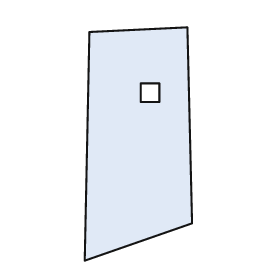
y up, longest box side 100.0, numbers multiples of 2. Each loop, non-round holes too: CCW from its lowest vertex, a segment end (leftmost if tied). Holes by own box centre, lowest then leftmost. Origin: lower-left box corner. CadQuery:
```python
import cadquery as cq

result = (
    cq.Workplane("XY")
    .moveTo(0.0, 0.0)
    .lineTo(46.0, 16.0)
    .lineTo(44.0, 100.0)
    .lineTo(2.0, 98.0)
    .close()
    .moveTo(24.0, 68.0)
    .lineTo(32.0, 68.0)
    .lineTo(32.0, 76.0)
    .lineTo(24.0, 76.0)
    .close()
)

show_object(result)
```